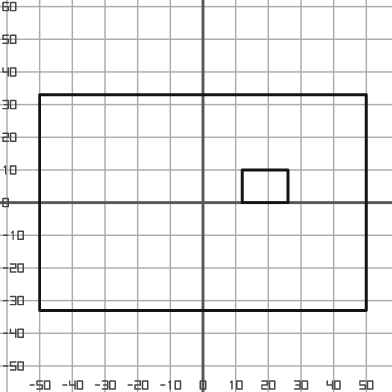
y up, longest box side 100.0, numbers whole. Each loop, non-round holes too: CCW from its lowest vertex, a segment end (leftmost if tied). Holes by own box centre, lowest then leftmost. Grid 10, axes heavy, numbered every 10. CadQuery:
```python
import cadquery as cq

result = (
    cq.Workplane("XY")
    .moveTo(-50.0, -33.0)
    .lineTo(50.0, -33.0)
    .lineTo(50.0, 33.0)
    .lineTo(-50.0, 33.0)
    .close()
    .moveTo(12.0, 0.0)
    .lineTo(26.0, 0.0)
    .lineTo(26.0, 10.0)
    .lineTo(12.0, 10.0)
    .close()
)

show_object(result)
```